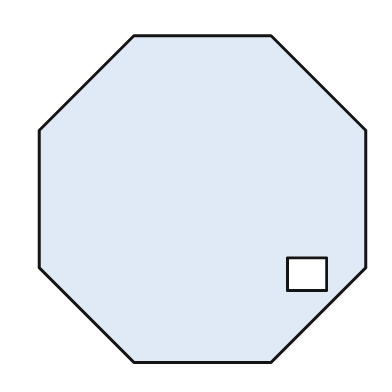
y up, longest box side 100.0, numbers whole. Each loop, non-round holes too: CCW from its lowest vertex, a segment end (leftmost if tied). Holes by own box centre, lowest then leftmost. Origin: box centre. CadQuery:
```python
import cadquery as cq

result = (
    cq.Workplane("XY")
    .moveTo(-21.0, -50.0)
    .lineTo(21.0, -50.0)
    .lineTo(50.0, -21.0)
    .lineTo(50.0, 21.0)
    .lineTo(21.0, 50.0)
    .lineTo(-21.0, 50.0)
    .lineTo(-50.0, 21.0)
    .lineTo(-50.0, -21.0)
    .close()
    .moveTo(26.0, -28.0)
    .lineTo(38.0, -28.0)
    .lineTo(38.0, -18.0)
    .lineTo(26.0, -18.0)
    .close()
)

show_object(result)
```